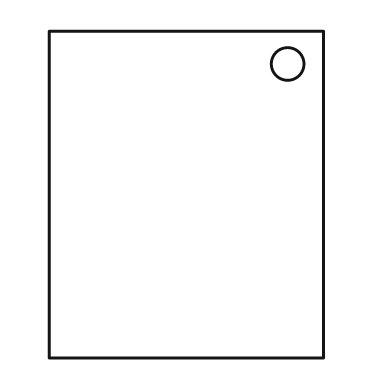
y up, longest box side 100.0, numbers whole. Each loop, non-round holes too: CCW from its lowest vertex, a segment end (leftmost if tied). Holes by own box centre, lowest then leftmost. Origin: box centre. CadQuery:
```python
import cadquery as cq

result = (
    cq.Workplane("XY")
    .moveTo(-42.0, -50.0)
    .lineTo(42.0, -50.0)
    .lineTo(42.0, 50.0)
    .lineTo(-42.0, 50.0)
    .close()
    .moveTo(31.0, 40.0)
    .circle(5.0)
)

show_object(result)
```